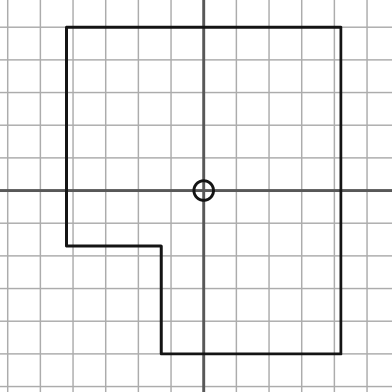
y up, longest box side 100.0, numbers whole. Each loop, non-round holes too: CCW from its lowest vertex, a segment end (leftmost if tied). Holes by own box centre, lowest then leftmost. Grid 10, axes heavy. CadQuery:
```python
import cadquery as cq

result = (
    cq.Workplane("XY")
    .moveTo(-13.0, -50.0)
    .lineTo(42.0, -50.0)
    .lineTo(42.0, 50.0)
    .lineTo(-42.0, 50.0)
    .lineTo(-42.0, -17.0)
    .lineTo(-13.0, -17.0)
    .close()
    .moveTo(0.0, 0.0)
    .circle(3.0)
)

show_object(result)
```